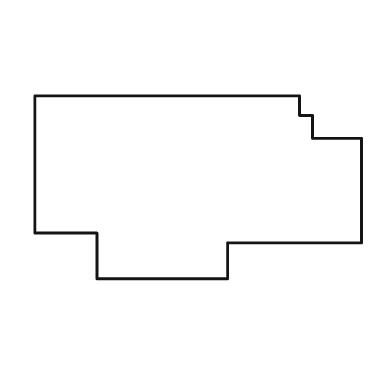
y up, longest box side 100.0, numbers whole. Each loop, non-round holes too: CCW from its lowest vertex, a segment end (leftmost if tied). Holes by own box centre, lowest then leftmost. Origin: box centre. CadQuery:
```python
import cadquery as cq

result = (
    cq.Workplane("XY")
    .moveTo(-31.0, -28.0)
    .lineTo(9.0, -28.0)
    .lineTo(9.0, -17.0)
    .lineTo(50.0, -17.0)
    .lineTo(50.0, 15.0)
    .lineTo(35.0, 15.0)
    .lineTo(35.0, 22.0)
    .lineTo(31.0, 22.0)
    .lineTo(31.0, 28.0)
    .lineTo(-50.0, 28.0)
    .lineTo(-50.0, -14.0)
    .lineTo(-31.0, -14.0)
    .close()
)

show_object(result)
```